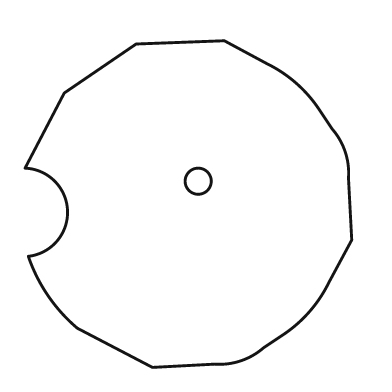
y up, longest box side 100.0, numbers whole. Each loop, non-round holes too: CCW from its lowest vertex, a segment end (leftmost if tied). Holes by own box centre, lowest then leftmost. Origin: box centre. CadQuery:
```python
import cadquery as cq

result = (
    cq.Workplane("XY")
    .moveTo(-11.0, -50.0)
    .lineTo(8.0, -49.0)
    .threePointArc((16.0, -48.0), (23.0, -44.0))
    .lineTo(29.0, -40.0)
    .threePointArc((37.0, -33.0), (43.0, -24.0))
    .lineTo(50.0, -11.0)
    .lineTo(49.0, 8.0)
    .threePointArc((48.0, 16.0), (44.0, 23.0))
    .lineTo(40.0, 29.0)
    .threePointArc((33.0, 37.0), (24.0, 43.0))
    .lineTo(11.0, 50.0)
    .lineTo(-16.0, 49.0)
    .lineTo(-38.0, 34.0)
    .lineTo(-50.0, 11.0)
    .threePointArc((-37.0, -2.0), (-49.0, -16.0))
    .threePointArc((-43.0, -28.0), (-34.0, -38.0))
    .close()
    .moveTo(3.0, 7.0)
    .circle(4.0)
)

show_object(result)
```